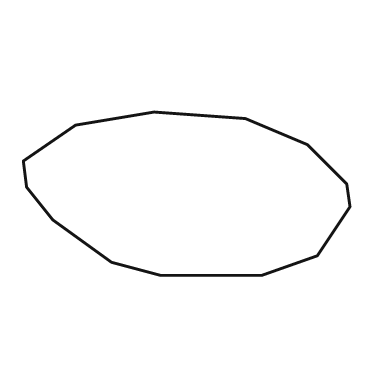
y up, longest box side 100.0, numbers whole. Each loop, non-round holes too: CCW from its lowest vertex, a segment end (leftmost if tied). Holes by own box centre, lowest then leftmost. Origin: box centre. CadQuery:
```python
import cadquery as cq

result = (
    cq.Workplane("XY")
    .moveTo(-8.0, -25.0)
    .lineTo(23.0, -25.0)
    .lineTo(40.0, -19.0)
    .lineTo(50.0, -4.0)
    .lineTo(49.0, 3.0)
    .lineTo(37.0, 15.0)
    .lineTo(18.0, 23.0)
    .lineTo(-10.0, 25.0)
    .lineTo(-34.0, 21.0)
    .lineTo(-50.0, 10.0)
    .lineTo(-49.0, 2.0)
    .lineTo(-41.0, -8.0)
    .lineTo(-23.0, -21.0)
    .close()
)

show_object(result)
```